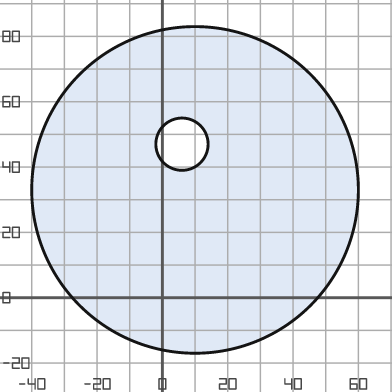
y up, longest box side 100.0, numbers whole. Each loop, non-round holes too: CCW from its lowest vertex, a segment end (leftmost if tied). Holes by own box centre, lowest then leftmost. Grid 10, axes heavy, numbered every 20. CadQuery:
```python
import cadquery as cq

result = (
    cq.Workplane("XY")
    .moveTo(10.0, 33.0)
    .circle(50.0)
    .moveTo(6.0, 47.0)
    .circle(8.0)
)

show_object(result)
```